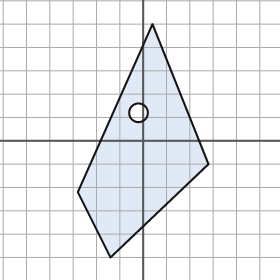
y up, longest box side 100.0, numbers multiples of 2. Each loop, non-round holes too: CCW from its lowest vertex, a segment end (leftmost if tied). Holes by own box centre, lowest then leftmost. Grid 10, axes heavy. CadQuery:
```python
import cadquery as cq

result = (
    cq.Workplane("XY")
    .moveTo(-14.0, -50.0)
    .lineTo(28.0, -10.0)
    .lineTo(4.0, 50.0)
    .lineTo(-28.0, -22.0)
    .close()
    .moveTo(-2.0, 12.0)
    .circle(4.0)
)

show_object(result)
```